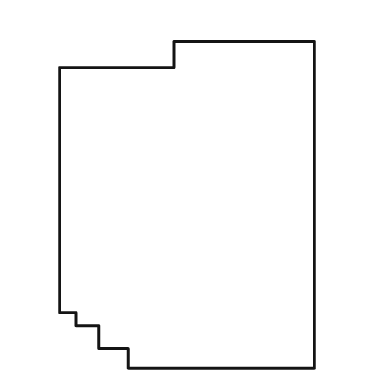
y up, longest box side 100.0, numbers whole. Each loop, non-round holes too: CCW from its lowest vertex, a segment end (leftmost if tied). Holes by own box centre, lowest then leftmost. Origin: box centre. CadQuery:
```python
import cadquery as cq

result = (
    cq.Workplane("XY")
    .moveTo(-18.0, -50.0)
    .lineTo(39.0, -50.0)
    .lineTo(39.0, 50.0)
    .lineTo(-4.0, 50.0)
    .lineTo(-4.0, 42.0)
    .lineTo(-39.0, 42.0)
    .lineTo(-39.0, -33.0)
    .lineTo(-34.0, -33.0)
    .lineTo(-34.0, -37.0)
    .lineTo(-27.0, -37.0)
    .lineTo(-27.0, -44.0)
    .lineTo(-18.0, -44.0)
    .close()
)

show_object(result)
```